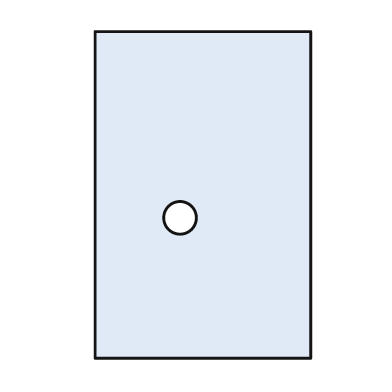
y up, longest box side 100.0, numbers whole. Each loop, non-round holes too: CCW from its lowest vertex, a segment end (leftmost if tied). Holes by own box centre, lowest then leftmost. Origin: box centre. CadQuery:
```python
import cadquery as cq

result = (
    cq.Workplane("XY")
    .moveTo(-33.0, -50.0)
    .lineTo(33.0, -50.0)
    .lineTo(33.0, 50.0)
    .lineTo(-33.0, 50.0)
    .close()
    .moveTo(-7.0, -7.0)
    .circle(5.0)
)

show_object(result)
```